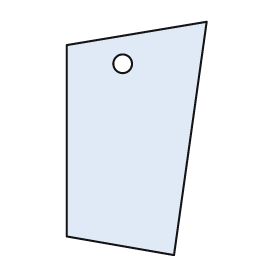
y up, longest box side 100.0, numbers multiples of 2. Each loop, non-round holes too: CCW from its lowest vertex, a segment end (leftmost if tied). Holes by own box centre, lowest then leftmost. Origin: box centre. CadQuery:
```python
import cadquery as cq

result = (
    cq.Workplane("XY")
    .moveTo(16.0, -50.0)
    .lineTo(30.0, 50.0)
    .lineTo(-30.0, 40.0)
    .lineTo(-30.0, -42.0)
    .close()
    .moveTo(-6.0, 32.0)
    .circle(4.0)
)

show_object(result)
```